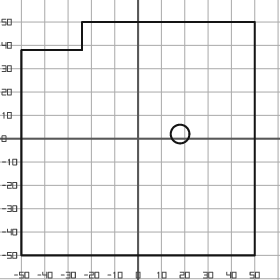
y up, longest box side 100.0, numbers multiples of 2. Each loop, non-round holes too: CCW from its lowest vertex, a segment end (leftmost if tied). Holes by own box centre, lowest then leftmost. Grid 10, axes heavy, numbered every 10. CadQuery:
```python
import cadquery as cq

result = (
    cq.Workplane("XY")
    .moveTo(-50.0, -50.0)
    .lineTo(50.0, -50.0)
    .lineTo(50.0, 50.0)
    .lineTo(-24.0, 50.0)
    .lineTo(-24.0, 38.0)
    .lineTo(-50.0, 38.0)
    .close()
    .moveTo(18.0, 2.0)
    .circle(4.0)
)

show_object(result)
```